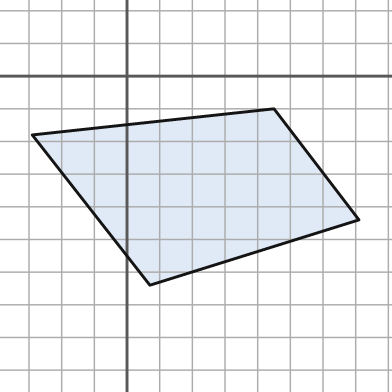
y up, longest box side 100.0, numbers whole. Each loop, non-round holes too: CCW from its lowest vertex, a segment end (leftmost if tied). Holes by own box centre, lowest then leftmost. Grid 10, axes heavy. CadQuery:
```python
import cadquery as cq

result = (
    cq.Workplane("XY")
    .moveTo(7.0, -64.0)
    .lineTo(71.0, -44.0)
    .lineTo(45.0, -10.0)
    .lineTo(-29.0, -18.0)
    .close()
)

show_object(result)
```